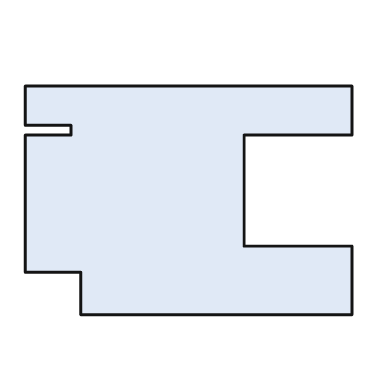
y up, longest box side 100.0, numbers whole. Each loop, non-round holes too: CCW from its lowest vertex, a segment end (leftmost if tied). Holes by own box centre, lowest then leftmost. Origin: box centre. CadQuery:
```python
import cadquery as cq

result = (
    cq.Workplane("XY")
    .moveTo(-33.0, -35.0)
    .lineTo(50.0, -35.0)
    .lineTo(50.0, -14.0)
    .lineTo(17.0, -14.0)
    .lineTo(17.0, 20.0)
    .lineTo(50.0, 20.0)
    .lineTo(50.0, 35.0)
    .lineTo(-50.0, 35.0)
    .lineTo(-50.0, 23.0)
    .lineTo(-36.0, 23.0)
    .lineTo(-36.0, 20.0)
    .lineTo(-50.0, 20.0)
    .lineTo(-50.0, -22.0)
    .lineTo(-33.0, -22.0)
    .close()
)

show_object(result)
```